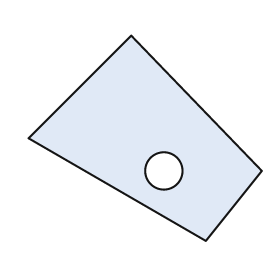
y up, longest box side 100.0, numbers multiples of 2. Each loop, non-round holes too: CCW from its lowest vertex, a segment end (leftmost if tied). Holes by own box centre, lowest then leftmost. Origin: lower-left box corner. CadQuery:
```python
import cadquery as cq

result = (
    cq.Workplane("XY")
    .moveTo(76.0, 0.0)
    .lineTo(100.0, 30.0)
    .lineTo(44.0, 88.0)
    .lineTo(0.0, 44.0)
    .close()
    .moveTo(58.0, 30.0)
    .circle(8.0)
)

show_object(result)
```